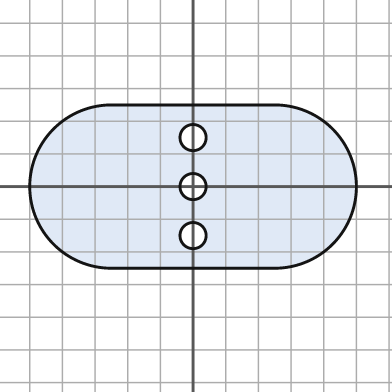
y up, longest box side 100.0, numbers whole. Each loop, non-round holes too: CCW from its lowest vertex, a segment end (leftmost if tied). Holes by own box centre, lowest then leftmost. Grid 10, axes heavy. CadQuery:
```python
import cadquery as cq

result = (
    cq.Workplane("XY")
    .moveTo(-25.0, -25.0)
    .lineTo(25.0, -25.0)
    .threePointArc((50.0, 0.0), (25.0, 25.0))
    .lineTo(-25.0, 25.0)
    .threePointArc((-50.0, 0.0), (-25.0, -25.0))
    .close()
    .moveTo(0.0, -15.0)
    .circle(4.0)
    .moveTo(0.0, 0.0)
    .circle(4.0)
    .moveTo(0.0, 15.0)
    .circle(4.0)
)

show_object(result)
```